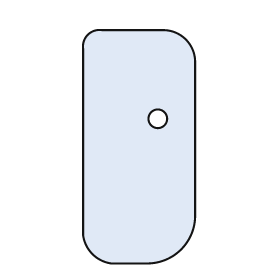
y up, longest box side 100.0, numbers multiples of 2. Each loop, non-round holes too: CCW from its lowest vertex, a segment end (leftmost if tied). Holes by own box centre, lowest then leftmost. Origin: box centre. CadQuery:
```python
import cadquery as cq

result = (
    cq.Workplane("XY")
    .moveTo(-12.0, -50.0)
    .lineTo(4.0, -50.0)
    .threePointArc((18.0, -44.0), (24.0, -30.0))
    .lineTo(24.0, 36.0)
    .threePointArc((20.0, 46.0), (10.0, 50.0))
    .lineTo(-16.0, 50.0)
    .threePointArc((-22.0, 48.0), (-24.0, 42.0))
    .lineTo(-24.0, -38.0)
    .threePointArc((-20.0, -46.0), (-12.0, -50.0))
    .close()
    .moveTo(8.0, 12.0)
    .circle(4.0)
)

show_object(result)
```